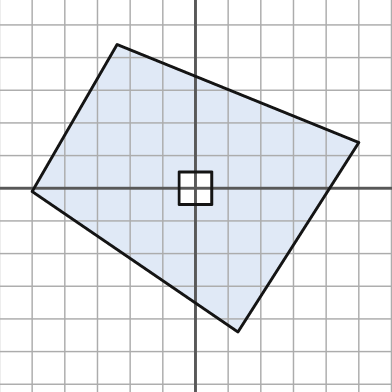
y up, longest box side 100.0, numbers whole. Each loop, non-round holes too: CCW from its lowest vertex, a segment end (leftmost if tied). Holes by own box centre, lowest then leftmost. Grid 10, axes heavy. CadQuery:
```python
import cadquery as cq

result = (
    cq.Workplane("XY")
    .moveTo(13.0, -44.0)
    .lineTo(50.0, 14.0)
    .lineTo(-24.0, 44.0)
    .lineTo(-50.0, -1.0)
    .close()
    .moveTo(-5.0, -5.0)
    .lineTo(5.0, -5.0)
    .lineTo(5.0, 5.0)
    .lineTo(-5.0, 5.0)
    .close()
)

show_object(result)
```